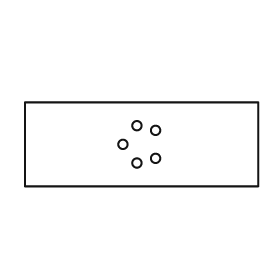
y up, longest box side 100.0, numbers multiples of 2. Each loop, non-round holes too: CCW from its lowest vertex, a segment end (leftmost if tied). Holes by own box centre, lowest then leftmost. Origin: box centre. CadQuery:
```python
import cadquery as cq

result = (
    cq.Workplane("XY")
    .moveTo(-50.0, -18.0)
    .lineTo(50.0, -18.0)
    .lineTo(50.0, 18.0)
    .lineTo(-50.0, 18.0)
    .close()
    .moveTo(-2.0, -8.0)
    .circle(2.0)
    .moveTo(6.0, -6.0)
    .circle(2.0)
    .moveTo(-8.0, 0.0)
    .circle(2.0)
    .moveTo(6.0, 6.0)
    .circle(2.0)
    .moveTo(-2.0, 8.0)
    .circle(2.0)
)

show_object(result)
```